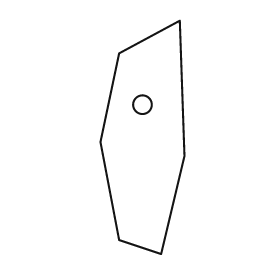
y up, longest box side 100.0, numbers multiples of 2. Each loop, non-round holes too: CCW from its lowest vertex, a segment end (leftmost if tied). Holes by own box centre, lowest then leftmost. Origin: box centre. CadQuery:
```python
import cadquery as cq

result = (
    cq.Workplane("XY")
    .moveTo(8.0, -50.0)
    .lineTo(18.0, -8.0)
    .lineTo(16.0, 50.0)
    .lineTo(-10.0, 36.0)
    .lineTo(-18.0, -2.0)
    .lineTo(-10.0, -44.0)
    .close()
    .moveTo(0.0, 14.0)
    .circle(4.0)
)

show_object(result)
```